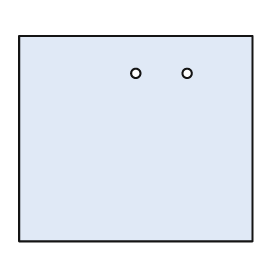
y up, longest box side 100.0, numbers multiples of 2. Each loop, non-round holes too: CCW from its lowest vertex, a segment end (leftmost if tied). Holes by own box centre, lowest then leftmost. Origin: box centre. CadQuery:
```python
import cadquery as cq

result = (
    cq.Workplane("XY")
    .moveTo(-50.0, -44.0)
    .lineTo(50.0, -44.0)
    .lineTo(50.0, 44.0)
    .lineTo(-50.0, 44.0)
    .close()
    .moveTo(0.0, 28.0)
    .circle(2.0)
    .moveTo(22.0, 28.0)
    .circle(2.0)
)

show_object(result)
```